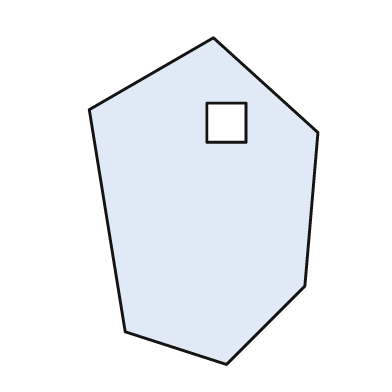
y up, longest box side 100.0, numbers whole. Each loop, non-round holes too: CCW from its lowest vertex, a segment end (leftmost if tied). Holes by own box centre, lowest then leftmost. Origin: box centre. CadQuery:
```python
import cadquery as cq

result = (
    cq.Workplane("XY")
    .moveTo(7.0, -50.0)
    .lineTo(31.0, -26.0)
    .lineTo(35.0, 21.0)
    .lineTo(3.0, 50.0)
    .lineTo(-35.0, 28.0)
    .lineTo(-24.0, -40.0)
    .close()
    .moveTo(1.0, 18.0)
    .lineTo(13.0, 18.0)
    .lineTo(13.0, 30.0)
    .lineTo(1.0, 30.0)
    .close()
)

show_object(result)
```